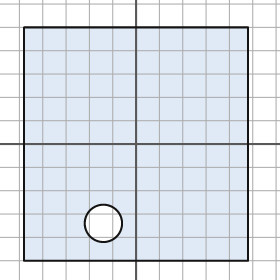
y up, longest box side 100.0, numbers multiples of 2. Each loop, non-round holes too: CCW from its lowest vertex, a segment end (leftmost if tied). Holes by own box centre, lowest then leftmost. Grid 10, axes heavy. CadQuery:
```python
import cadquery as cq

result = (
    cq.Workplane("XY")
    .moveTo(-48.0, -50.0)
    .lineTo(48.0, -50.0)
    .lineTo(48.0, 50.0)
    .lineTo(-48.0, 50.0)
    .close()
    .moveTo(-14.0, -34.0)
    .circle(8.0)
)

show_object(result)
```